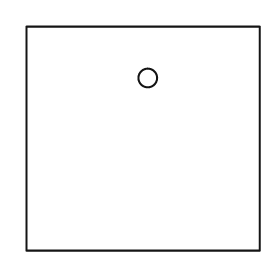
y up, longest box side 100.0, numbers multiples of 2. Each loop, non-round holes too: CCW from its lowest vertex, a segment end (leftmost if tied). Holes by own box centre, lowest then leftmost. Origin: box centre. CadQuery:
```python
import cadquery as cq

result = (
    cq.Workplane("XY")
    .moveTo(-50.0, -48.0)
    .lineTo(50.0, -48.0)
    .lineTo(50.0, 48.0)
    .lineTo(-50.0, 48.0)
    .close()
    .moveTo(2.0, 26.0)
    .circle(4.0)
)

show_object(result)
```